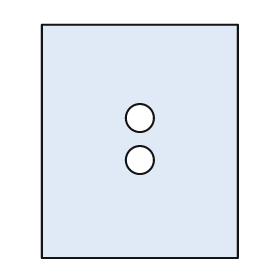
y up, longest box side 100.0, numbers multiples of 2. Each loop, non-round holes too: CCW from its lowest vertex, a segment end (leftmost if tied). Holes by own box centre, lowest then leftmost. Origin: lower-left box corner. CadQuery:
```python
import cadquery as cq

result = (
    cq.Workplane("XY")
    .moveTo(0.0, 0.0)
    .lineTo(84.0, 0.0)
    .lineTo(84.0, 100.0)
    .lineTo(0.0, 100.0)
    .close()
    .moveTo(42.0, 42.0)
    .circle(6.0)
    .moveTo(42.0, 60.0)
    .circle(6.0)
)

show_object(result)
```